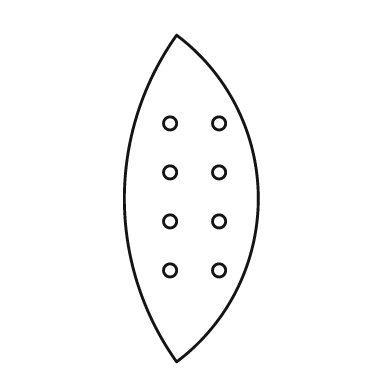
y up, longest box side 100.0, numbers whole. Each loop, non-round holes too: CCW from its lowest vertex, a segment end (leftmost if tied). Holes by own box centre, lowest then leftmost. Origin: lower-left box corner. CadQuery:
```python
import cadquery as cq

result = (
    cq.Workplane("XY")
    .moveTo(16.0, 0.0)
    .threePointArc((41.0, 50.0), (16.0, 100.0))
    .threePointArc((0.0, 50.0), (16.0, 0.0))
    .close()
    .moveTo(14.0, 28.0)
    .circle(2.0)
    .moveTo(29.0, 28.0)
    .circle(2.0)
    .moveTo(14.0, 43.0)
    .circle(2.0)
    .moveTo(29.0, 43.0)
    .circle(2.0)
    .moveTo(14.0, 58.0)
    .circle(2.0)
    .moveTo(29.0, 58.0)
    .circle(2.0)
    .moveTo(14.0, 73.0)
    .circle(2.0)
    .moveTo(29.0, 73.0)
    .circle(2.0)
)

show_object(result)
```